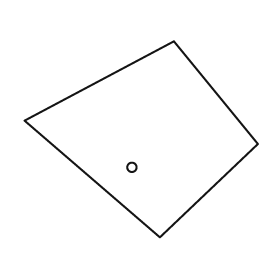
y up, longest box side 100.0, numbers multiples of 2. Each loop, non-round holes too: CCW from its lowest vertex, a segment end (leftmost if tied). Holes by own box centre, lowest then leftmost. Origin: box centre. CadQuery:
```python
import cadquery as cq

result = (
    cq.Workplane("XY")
    .moveTo(8.0, -42.0)
    .lineTo(50.0, -2.0)
    .lineTo(14.0, 42.0)
    .lineTo(-50.0, 8.0)
    .close()
    .moveTo(-4.0, -12.0)
    .circle(2.0)
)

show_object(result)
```